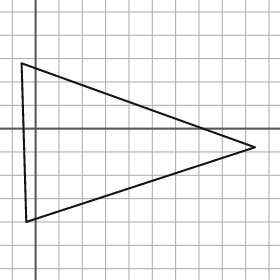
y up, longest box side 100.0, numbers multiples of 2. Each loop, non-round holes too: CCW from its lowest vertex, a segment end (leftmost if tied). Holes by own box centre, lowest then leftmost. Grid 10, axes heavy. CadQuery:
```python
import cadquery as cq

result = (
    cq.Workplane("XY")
    .moveTo(-4.0, -40.0)
    .lineTo(94.0, -8.0)
    .lineTo(-6.0, 28.0)
    .close()
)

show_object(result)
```